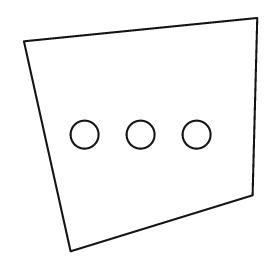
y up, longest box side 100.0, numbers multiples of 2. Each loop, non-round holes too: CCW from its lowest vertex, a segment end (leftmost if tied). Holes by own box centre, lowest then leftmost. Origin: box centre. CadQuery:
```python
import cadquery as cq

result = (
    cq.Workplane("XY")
    .moveTo(-30.0, -50.0)
    .lineTo(48.0, -26.0)
    .lineTo(50.0, 50.0)
    .lineTo(-50.0, 40.0)
    .close()
    .moveTo(-24.0, 0.0)
    .circle(6.0)
    .moveTo(0.0, 0.0)
    .circle(6.0)
    .moveTo(24.0, 0.0)
    .circle(6.0)
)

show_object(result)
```